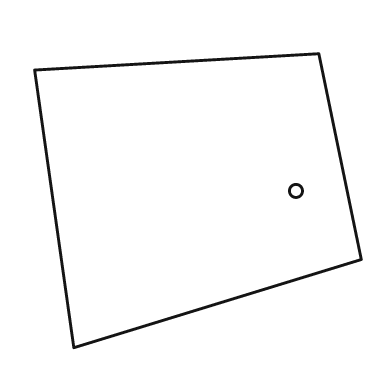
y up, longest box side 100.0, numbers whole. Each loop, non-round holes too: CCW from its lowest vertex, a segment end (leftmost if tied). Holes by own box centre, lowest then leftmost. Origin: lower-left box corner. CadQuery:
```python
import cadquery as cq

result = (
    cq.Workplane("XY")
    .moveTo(12.0, 0.0)
    .lineTo(100.0, 27.0)
    .lineTo(87.0, 90.0)
    .lineTo(0.0, 85.0)
    .close()
    .moveTo(80.0, 48.0)
    .circle(2.0)
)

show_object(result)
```